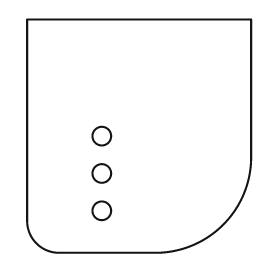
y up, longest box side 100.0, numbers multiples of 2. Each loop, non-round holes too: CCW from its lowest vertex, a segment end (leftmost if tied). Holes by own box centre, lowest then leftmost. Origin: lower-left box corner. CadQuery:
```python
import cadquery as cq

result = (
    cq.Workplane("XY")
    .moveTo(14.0, 0.0)
    .lineTo(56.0, 0.0)
    .threePointArc((84.0, 12.0), (96.0, 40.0))
    .lineTo(96.0, 100.0)
    .lineTo(0.0, 100.0)
    .lineTo(0.0, 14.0)
    .threePointArc((4.0, 4.0), (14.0, 0.0))
    .close()
    .moveTo(32.0, 18.0)
    .circle(4.0)
    .moveTo(32.0, 34.0)
    .circle(4.0)
    .moveTo(32.0, 50.0)
    .circle(4.0)
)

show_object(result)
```